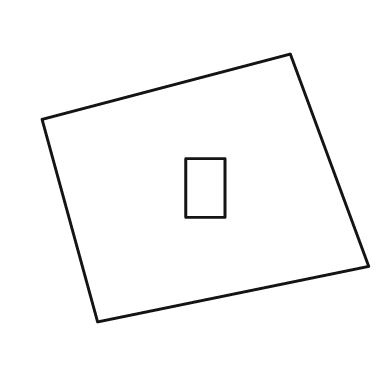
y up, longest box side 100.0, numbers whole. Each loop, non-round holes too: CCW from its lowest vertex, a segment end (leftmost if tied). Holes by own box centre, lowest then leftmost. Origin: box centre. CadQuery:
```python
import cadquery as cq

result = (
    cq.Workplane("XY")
    .moveTo(-33.0, -41.0)
    .lineTo(50.0, -24.0)
    .lineTo(26.0, 41.0)
    .lineTo(-50.0, 21.0)
    .close()
    .moveTo(-6.0, -9.0)
    .lineTo(6.0, -9.0)
    .lineTo(6.0, 9.0)
    .lineTo(-6.0, 9.0)
    .close()
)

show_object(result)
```